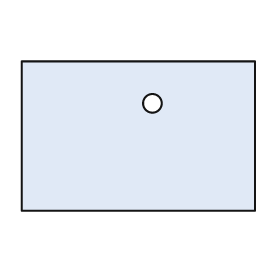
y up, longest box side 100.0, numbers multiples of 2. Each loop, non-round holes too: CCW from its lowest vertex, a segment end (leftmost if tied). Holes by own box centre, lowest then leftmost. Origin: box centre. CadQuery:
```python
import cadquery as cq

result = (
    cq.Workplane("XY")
    .moveTo(-50.0, -32.0)
    .lineTo(50.0, -32.0)
    .lineTo(50.0, 32.0)
    .lineTo(-50.0, 32.0)
    .close()
    .moveTo(6.0, 14.0)
    .circle(4.0)
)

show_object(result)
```